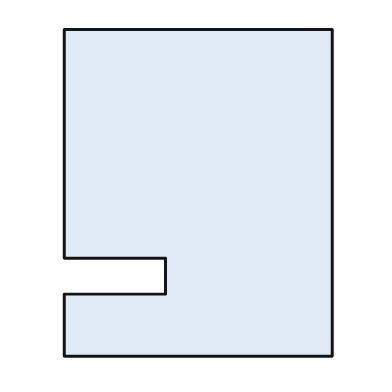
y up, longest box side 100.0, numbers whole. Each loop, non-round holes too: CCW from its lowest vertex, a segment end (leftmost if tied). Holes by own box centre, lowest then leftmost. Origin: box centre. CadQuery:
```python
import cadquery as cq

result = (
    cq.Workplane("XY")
    .moveTo(-41.0, -50.0)
    .lineTo(41.0, -50.0)
    .lineTo(41.0, 50.0)
    .lineTo(-41.0, 50.0)
    .lineTo(-41.0, -20.0)
    .lineTo(-10.0, -20.0)
    .lineTo(-10.0, -31.0)
    .lineTo(-41.0, -31.0)
    .close()
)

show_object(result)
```